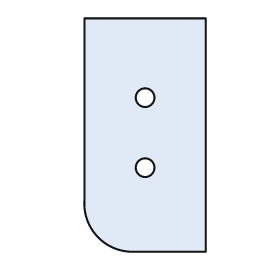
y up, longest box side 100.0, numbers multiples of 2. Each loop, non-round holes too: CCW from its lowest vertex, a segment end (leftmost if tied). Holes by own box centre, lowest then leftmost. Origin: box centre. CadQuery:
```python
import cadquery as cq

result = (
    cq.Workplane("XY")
    .moveTo(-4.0, -50.0)
    .lineTo(26.0, -50.0)
    .lineTo(26.0, 50.0)
    .lineTo(-26.0, 50.0)
    .lineTo(-26.0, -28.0)
    .threePointArc((-20.0, -44.0), (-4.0, -50.0))
    .close()
    .moveTo(0.0, -14.0)
    .circle(4.0)
    .moveTo(0.0, 16.0)
    .circle(4.0)
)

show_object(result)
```